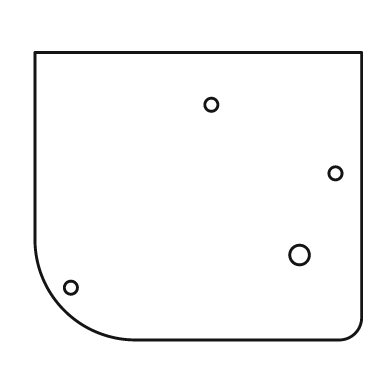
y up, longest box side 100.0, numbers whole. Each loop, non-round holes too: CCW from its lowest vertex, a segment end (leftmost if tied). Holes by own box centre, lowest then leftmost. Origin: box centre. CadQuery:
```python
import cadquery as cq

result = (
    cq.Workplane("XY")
    .moveTo(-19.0, -44.0)
    .lineTo(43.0, -44.0)
    .threePointArc((48.0, -42.0), (50.0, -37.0))
    .lineTo(50.0, 44.0)
    .lineTo(-50.0, 44.0)
    .lineTo(-50.0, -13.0)
    .threePointArc((-41.0, -35.0), (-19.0, -44.0))
    .close()
    .moveTo(-39.0, -28.0)
    .circle(2.0)
    .moveTo(31.0, -18.0)
    .circle(3.0)
    .moveTo(42.0, 7.0)
    .circle(2.0)
    .moveTo(4.0, 28.0)
    .circle(2.0)
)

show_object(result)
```